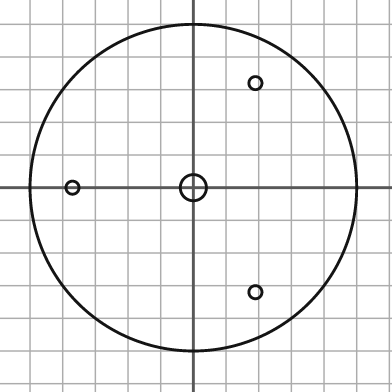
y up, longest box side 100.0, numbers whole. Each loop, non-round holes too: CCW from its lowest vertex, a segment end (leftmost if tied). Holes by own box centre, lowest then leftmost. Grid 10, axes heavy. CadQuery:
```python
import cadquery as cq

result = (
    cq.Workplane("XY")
    .moveTo(0.0, 0.0)
    .circle(50.0)
    .moveTo(19.0, -32.0)
    .circle(2.0)
    .moveTo(-37.0, 0.0)
    .circle(2.0)
    .moveTo(0.0, 0.0)
    .circle(4.0)
    .moveTo(19.0, 32.0)
    .circle(2.0)
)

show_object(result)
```